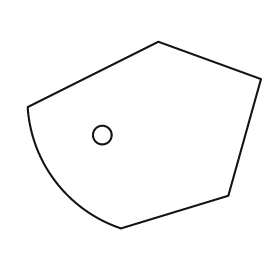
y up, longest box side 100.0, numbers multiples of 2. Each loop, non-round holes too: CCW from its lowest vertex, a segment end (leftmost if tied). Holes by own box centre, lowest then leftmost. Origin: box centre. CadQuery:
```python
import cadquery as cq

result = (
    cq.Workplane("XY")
    .moveTo(-10.0, -40.0)
    .lineTo(36.0, -26.0)
    .lineTo(50.0, 24.0)
    .lineTo(6.0, 40.0)
    .lineTo(-50.0, 12.0)
    .threePointArc((-38.0, -20.0), (-10.0, -40.0))
    .close()
    .moveTo(-18.0, 0.0)
    .circle(4.0)
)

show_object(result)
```